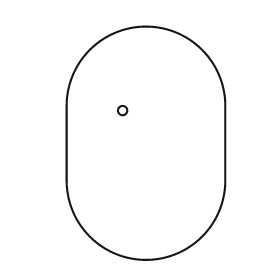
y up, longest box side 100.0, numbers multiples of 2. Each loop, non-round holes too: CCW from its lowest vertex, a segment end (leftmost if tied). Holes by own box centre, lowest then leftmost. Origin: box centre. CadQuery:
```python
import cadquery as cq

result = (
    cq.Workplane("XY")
    .moveTo(-34.0, -16.0)
    .threePointArc((0.0, -50.0), (34.0, -16.0))
    .lineTo(34.0, 16.0)
    .threePointArc((0.0, 50.0), (-34.0, 16.0))
    .close()
    .moveTo(-10.0, 14.0)
    .circle(2.0)
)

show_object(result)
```